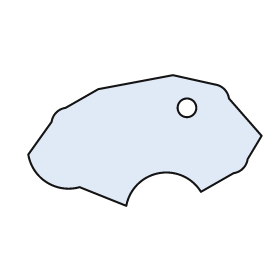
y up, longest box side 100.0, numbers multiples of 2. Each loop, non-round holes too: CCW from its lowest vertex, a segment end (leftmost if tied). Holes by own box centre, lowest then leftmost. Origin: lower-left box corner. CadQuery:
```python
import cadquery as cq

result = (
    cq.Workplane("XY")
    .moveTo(42.0, 0.0)
    .threePointArc((56.0, 14.0), (74.0, 6.0))
    .lineTo(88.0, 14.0)
    .threePointArc((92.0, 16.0), (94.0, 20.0))
    .lineTo(100.0, 30.0)
    .lineTo(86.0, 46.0)
    .threePointArc((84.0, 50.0), (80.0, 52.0))
    .lineTo(62.0, 56.0)
    .lineTo(30.0, 50.0)
    .lineTo(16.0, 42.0)
    .threePointArc((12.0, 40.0), (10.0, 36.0))
    .lineTo(0.0, 22.0)
    .threePointArc((8.0, 10.0), (22.0, 8.0))
    .close()
    .moveTo(68.0, 42.0)
    .circle(4.0)
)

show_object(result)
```